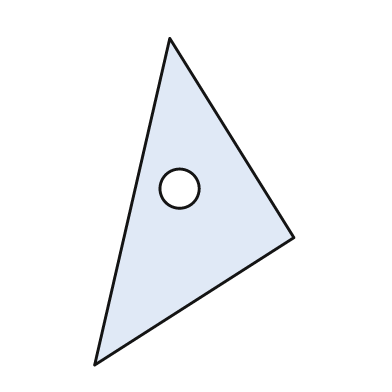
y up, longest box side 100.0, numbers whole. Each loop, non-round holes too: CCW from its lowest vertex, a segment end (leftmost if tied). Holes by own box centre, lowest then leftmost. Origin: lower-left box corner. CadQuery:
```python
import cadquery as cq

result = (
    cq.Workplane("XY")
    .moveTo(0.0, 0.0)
    .lineTo(61.0, 39.0)
    .lineTo(23.0, 100.0)
    .close()
    .moveTo(26.0, 54.0)
    .circle(6.0)
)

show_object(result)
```